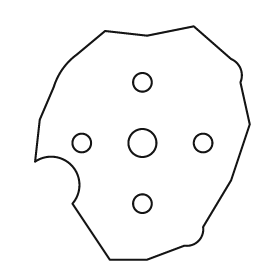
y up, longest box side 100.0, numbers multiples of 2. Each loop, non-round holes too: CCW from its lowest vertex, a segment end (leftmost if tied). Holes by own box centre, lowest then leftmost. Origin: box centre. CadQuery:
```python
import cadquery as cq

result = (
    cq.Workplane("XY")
    .moveTo(-14.0, -50.0)
    .lineTo(2.0, -50.0)
    .lineTo(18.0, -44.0)
    .threePointArc((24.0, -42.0), (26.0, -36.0))
    .lineTo(38.0, -16.0)
    .lineTo(46.0, 8.0)
    .lineTo(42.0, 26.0)
    .threePointArc((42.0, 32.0), (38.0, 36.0))
    .lineTo(22.0, 50.0)
    .lineTo(2.0, 46.0)
    .lineTo(-16.0, 48.0)
    .lineTo(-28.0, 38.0)
    .threePointArc((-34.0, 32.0), (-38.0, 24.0))
    .lineTo(-44.0, 10.0)
    .lineTo(-46.0, -8.0)
    .threePointArc((-30.0, -10.0), (-30.0, -26.0))
    .close()
    .moveTo(0.0, -26.0)
    .circle(4.0)
    .moveTo(-26.0, 0.0)
    .circle(4.0)
    .moveTo(0.0, 0.0)
    .circle(6.0)
    .moveTo(26.0, 0.0)
    .circle(4.0)
    .moveTo(0.0, 26.0)
    .circle(4.0)
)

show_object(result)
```